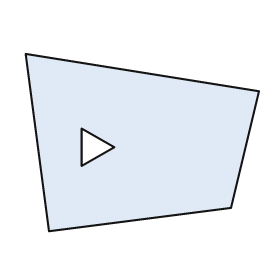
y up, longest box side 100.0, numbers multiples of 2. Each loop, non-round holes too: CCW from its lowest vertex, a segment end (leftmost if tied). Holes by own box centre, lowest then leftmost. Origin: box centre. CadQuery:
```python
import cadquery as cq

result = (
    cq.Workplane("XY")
    .moveTo(-40.0, -38.0)
    .lineTo(38.0, -28.0)
    .lineTo(50.0, 22.0)
    .lineTo(-50.0, 38.0)
    .close()
    .moveTo(-26.0, -10.0)
    .lineTo(-12.0, -2.0)
    .lineTo(-26.0, 6.0)
    .close()
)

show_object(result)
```